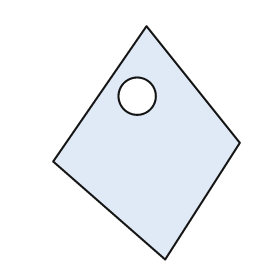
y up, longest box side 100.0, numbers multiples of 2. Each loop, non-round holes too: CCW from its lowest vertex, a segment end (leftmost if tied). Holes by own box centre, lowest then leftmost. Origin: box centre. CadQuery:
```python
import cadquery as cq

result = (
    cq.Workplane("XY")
    .moveTo(8.0, -50.0)
    .lineTo(40.0, 0.0)
    .lineTo(0.0, 50.0)
    .lineTo(-40.0, -8.0)
    .close()
    .moveTo(-4.0, 20.0)
    .circle(8.0)
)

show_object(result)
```